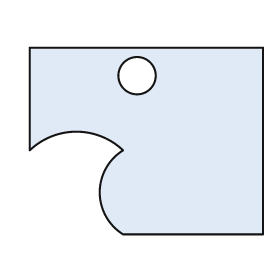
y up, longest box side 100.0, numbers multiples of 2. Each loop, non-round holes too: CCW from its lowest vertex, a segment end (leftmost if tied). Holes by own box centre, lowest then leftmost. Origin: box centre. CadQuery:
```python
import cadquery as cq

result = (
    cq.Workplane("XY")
    .moveTo(-10.0, -40.0)
    .lineTo(50.0, -40.0)
    .lineTo(50.0, 40.0)
    .lineTo(-50.0, 40.0)
    .lineTo(-50.0, -4.0)
    .threePointArc((-30.0, 4.0), (-10.0, -4.0))
    .threePointArc((-20.0, -22.0), (-10.0, -40.0))
    .close()
    .moveTo(-4.0, 28.0)
    .circle(8.0)
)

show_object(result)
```